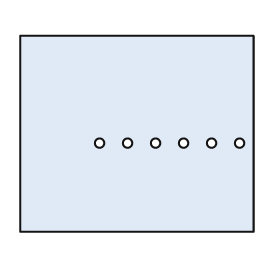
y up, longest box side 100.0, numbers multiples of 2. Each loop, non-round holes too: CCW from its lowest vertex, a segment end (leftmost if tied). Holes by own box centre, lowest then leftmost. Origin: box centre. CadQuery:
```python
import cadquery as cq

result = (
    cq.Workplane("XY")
    .moveTo(-50.0, -42.0)
    .lineTo(50.0, -42.0)
    .lineTo(50.0, 42.0)
    .lineTo(-50.0, 42.0)
    .close()
    .moveTo(-16.0, -4.0)
    .circle(2.0)
    .moveTo(-4.0, -4.0)
    .circle(2.0)
    .moveTo(8.0, -4.0)
    .circle(2.0)
    .moveTo(20.0, -4.0)
    .circle(2.0)
    .moveTo(32.0, -4.0)
    .circle(2.0)
    .moveTo(44.0, -4.0)
    .circle(2.0)
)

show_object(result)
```